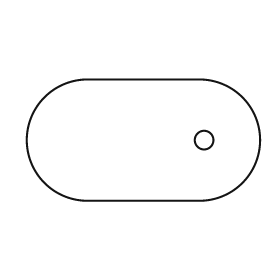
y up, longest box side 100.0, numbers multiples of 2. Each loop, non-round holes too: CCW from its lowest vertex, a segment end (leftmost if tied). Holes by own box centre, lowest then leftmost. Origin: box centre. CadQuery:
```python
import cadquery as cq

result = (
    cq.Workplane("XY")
    .moveTo(-24.0, -26.0)
    .lineTo(24.0, -26.0)
    .threePointArc((50.0, 0.0), (24.0, 26.0))
    .lineTo(-24.0, 26.0)
    .threePointArc((-50.0, 0.0), (-24.0, -26.0))
    .close()
    .moveTo(26.0, 0.0)
    .circle(4.0)
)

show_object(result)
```